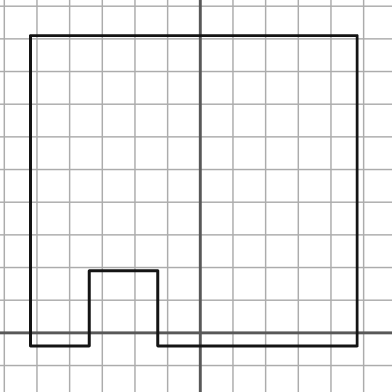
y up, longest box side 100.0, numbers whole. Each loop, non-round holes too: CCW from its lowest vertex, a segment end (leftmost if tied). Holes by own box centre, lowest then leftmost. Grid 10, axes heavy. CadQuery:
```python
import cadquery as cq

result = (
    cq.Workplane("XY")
    .moveTo(-52.0, -4.0)
    .lineTo(-34.0, -4.0)
    .lineTo(-34.0, 19.0)
    .lineTo(-13.0, 19.0)
    .lineTo(-13.0, -4.0)
    .lineTo(48.0, -4.0)
    .lineTo(48.0, 91.0)
    .lineTo(-52.0, 91.0)
    .close()
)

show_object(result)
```